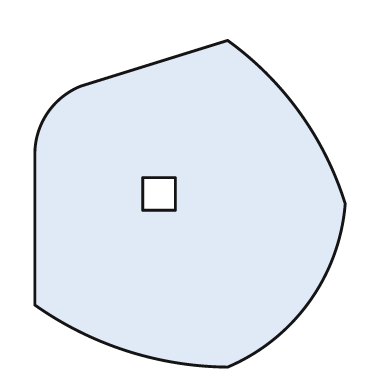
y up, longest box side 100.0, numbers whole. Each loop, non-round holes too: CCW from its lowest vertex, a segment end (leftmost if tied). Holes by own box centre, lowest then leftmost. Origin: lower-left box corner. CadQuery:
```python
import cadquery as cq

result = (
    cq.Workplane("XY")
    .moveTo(59.0, 0.0)
    .threePointArc((84.0, 20.0), (95.0, 50.0))
    .threePointArc((81.0, 78.0), (59.0, 100.0))
    .lineTo(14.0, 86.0)
    .threePointArc((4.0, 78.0), (0.0, 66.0))
    .lineTo(0.0, 19.0)
    .threePointArc((28.0, 5.0), (59.0, 0.0))
    .close()
    .moveTo(33.0, 48.0)
    .lineTo(43.0, 48.0)
    .lineTo(43.0, 58.0)
    .lineTo(33.0, 58.0)
    .close()
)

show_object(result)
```